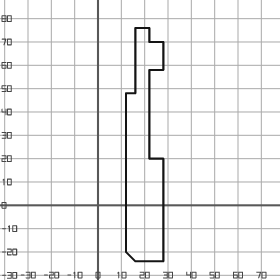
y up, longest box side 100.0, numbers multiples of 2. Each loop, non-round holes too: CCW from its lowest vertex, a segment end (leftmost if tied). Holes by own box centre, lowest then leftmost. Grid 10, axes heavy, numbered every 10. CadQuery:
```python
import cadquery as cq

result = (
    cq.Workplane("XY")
    .moveTo(16.0, -24.0)
    .lineTo(28.0, -24.0)
    .lineTo(28.0, 20.0)
    .lineTo(22.0, 20.0)
    .lineTo(22.0, 58.0)
    .lineTo(28.0, 58.0)
    .lineTo(28.0, 70.0)
    .lineTo(22.0, 70.0)
    .lineTo(22.0, 76.0)
    .lineTo(16.0, 76.0)
    .lineTo(16.0, 48.0)
    .lineTo(12.0, 48.0)
    .lineTo(12.0, -20.0)
    .close()
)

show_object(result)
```